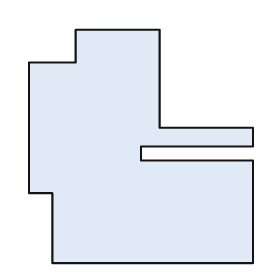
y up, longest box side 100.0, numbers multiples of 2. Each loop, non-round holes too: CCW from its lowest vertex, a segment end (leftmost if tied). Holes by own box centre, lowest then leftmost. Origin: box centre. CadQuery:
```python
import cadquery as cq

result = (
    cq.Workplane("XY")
    .moveTo(-38.0, -50.0)
    .lineTo(48.0, -50.0)
    .lineTo(48.0, -6.0)
    .lineTo(0.0, -6.0)
    .lineTo(0.0, 0.0)
    .lineTo(48.0, 0.0)
    .lineTo(48.0, 8.0)
    .lineTo(8.0, 8.0)
    .lineTo(8.0, 50.0)
    .lineTo(-28.0, 50.0)
    .lineTo(-28.0, 36.0)
    .lineTo(-48.0, 36.0)
    .lineTo(-48.0, -20.0)
    .lineTo(-38.0, -20.0)
    .close()
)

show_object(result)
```